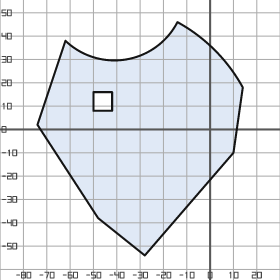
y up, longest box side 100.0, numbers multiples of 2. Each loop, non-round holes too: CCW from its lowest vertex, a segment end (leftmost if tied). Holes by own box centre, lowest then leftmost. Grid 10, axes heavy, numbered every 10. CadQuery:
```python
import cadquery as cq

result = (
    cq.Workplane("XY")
    .moveTo(-28.0, -54.0)
    .lineTo(10.0, -10.0)
    .lineTo(14.0, 18.0)
    .threePointArc((2.0, 34.0), (-14.0, 46.0))
    .threePointArc((-36.0, 30.0), (-62.0, 38.0))
    .lineTo(-74.0, 2.0)
    .lineTo(-48.0, -38.0)
    .close()
    .moveTo(-50.0, 8.0)
    .lineTo(-42.0, 8.0)
    .lineTo(-42.0, 16.0)
    .lineTo(-50.0, 16.0)
    .close()
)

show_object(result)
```